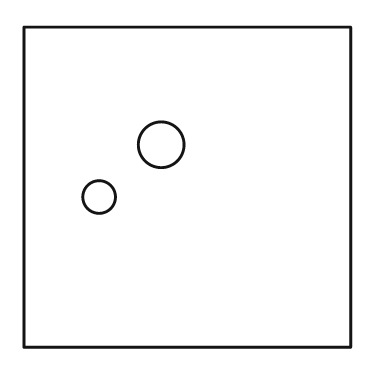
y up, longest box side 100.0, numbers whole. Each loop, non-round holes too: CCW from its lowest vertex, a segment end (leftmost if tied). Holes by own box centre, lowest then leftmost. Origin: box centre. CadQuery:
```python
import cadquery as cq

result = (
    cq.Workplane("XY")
    .moveTo(-50.0, -49.0)
    .lineTo(50.0, -49.0)
    .lineTo(50.0, 49.0)
    .lineTo(-50.0, 49.0)
    .close()
    .moveTo(-27.0, -3.0)
    .circle(5.0)
    .moveTo(-8.0, 13.0)
    .circle(7.0)
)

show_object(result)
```